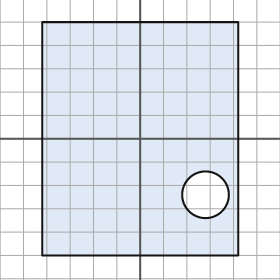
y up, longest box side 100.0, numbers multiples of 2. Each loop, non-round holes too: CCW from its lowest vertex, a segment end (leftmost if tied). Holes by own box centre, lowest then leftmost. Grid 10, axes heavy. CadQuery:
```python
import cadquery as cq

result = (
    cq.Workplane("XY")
    .moveTo(-42.0, -50.0)
    .lineTo(42.0, -50.0)
    .lineTo(42.0, 50.0)
    .lineTo(-42.0, 50.0)
    .close()
    .moveTo(28.0, -24.0)
    .circle(10.0)
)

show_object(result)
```